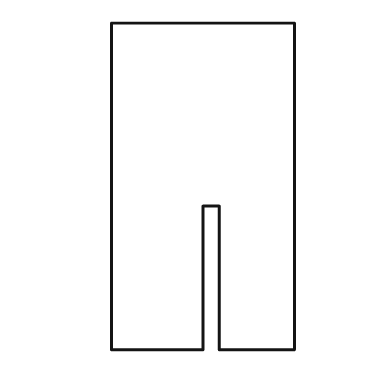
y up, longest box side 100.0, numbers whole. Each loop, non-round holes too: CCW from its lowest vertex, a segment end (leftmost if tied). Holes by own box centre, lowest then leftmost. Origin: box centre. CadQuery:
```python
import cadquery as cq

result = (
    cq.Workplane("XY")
    .moveTo(-28.0, -50.0)
    .lineTo(0.0, -50.0)
    .lineTo(0.0, -6.0)
    .lineTo(5.0, -6.0)
    .lineTo(5.0, -50.0)
    .lineTo(28.0, -50.0)
    .lineTo(28.0, 50.0)
    .lineTo(-28.0, 50.0)
    .close()
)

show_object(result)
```